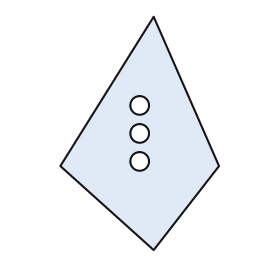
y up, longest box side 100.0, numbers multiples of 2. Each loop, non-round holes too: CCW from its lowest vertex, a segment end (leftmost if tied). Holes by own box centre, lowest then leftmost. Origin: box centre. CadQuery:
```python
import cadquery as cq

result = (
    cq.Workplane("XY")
    .moveTo(6.0, -50.0)
    .lineTo(34.0, -14.0)
    .lineTo(6.0, 50.0)
    .lineTo(-34.0, -14.0)
    .close()
    .moveTo(0.0, -12.0)
    .circle(4.0)
    .moveTo(0.0, 0.0)
    .circle(4.0)
    .moveTo(0.0, 12.0)
    .circle(4.0)
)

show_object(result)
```